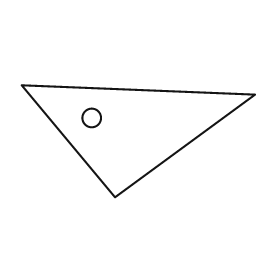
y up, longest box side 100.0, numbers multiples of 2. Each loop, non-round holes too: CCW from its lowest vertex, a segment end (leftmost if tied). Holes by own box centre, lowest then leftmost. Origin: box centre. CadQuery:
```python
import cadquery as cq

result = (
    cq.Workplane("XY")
    .moveTo(-10.0, -24.0)
    .lineTo(50.0, 20.0)
    .lineTo(-50.0, 24.0)
    .close()
    .moveTo(-20.0, 10.0)
    .circle(4.0)
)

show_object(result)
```